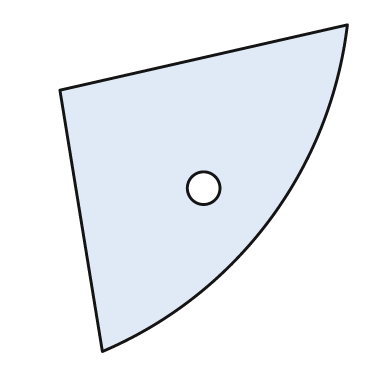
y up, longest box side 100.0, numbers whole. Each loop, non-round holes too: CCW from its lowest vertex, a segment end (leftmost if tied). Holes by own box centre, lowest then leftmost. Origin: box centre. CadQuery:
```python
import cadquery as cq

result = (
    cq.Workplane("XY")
    .moveTo(-31.0, -50.0)
    .threePointArc((20.0, -10.0), (44.0, 50.0))
    .lineTo(-44.0, 30.0)
    .close()
    .moveTo(0.0, 0.0)
    .circle(5.0)
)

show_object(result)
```